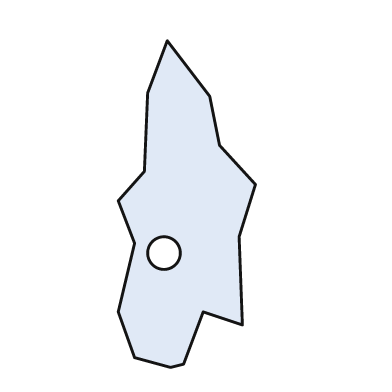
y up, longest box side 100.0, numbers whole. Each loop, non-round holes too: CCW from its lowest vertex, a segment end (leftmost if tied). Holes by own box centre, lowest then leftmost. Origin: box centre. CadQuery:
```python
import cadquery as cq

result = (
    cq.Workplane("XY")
    .moveTo(-5.0, -50.0)
    .lineTo(-1.0, -49.0)
    .lineTo(5.0, -33.0)
    .lineTo(17.0, -37.0)
    .lineTo(16.0, -10.0)
    .lineTo(21.0, 6.0)
    .lineTo(10.0, 18.0)
    .lineTo(7.0, 33.0)
    .lineTo(-6.0, 50.0)
    .lineTo(-12.0, 34.0)
    .lineTo(-13.0, 10.0)
    .lineTo(-21.0, 1.0)
    .lineTo(-16.0, -12.0)
    .lineTo(-21.0, -33.0)
    .lineTo(-16.0, -47.0)
    .close()
    .moveTo(-7.0, -15.0)
    .circle(5.0)
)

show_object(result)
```